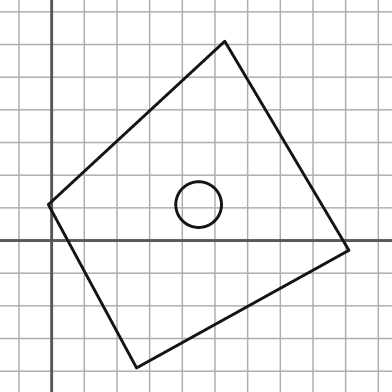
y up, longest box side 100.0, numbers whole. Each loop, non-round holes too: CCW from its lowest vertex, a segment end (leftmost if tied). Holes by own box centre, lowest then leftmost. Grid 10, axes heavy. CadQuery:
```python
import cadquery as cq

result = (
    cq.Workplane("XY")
    .moveTo(26.0, -39.0)
    .lineTo(91.0, -3.0)
    .lineTo(53.0, 61.0)
    .lineTo(-1.0, 11.0)
    .close()
    .moveTo(45.0, 11.0)
    .circle(7.0)
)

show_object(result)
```